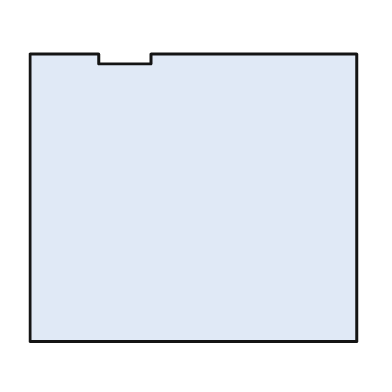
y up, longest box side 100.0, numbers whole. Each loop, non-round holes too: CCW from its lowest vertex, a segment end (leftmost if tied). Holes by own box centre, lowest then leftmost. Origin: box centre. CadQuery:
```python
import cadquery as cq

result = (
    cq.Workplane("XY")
    .moveTo(-50.0, -44.0)
    .lineTo(50.0, -44.0)
    .lineTo(50.0, 44.0)
    .lineTo(-13.0, 44.0)
    .lineTo(-13.0, 41.0)
    .lineTo(-29.0, 41.0)
    .lineTo(-29.0, 44.0)
    .lineTo(-50.0, 44.0)
    .close()
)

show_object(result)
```